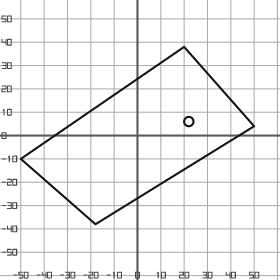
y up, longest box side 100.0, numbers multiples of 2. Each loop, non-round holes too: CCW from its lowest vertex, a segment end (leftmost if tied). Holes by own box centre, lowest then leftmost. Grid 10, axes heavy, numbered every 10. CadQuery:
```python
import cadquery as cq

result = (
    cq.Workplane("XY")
    .moveTo(-18.0, -38.0)
    .lineTo(50.0, 4.0)
    .lineTo(20.0, 38.0)
    .lineTo(-50.0, -10.0)
    .close()
    .moveTo(22.0, 6.0)
    .circle(2.0)
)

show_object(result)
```